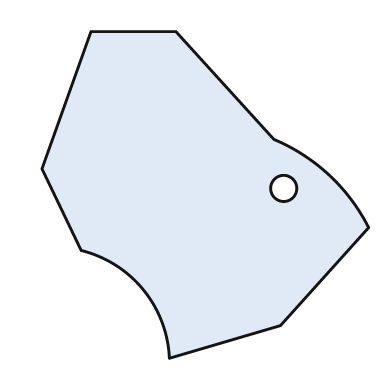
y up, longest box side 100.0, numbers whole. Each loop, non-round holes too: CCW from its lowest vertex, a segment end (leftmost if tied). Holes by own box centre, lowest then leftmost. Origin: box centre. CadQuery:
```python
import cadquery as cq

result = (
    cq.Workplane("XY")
    .moveTo(-11.0, -50.0)
    .lineTo(23.0, -40.0)
    .lineTo(50.0, -10.0)
    .threePointArc((38.0, 6.0), (21.0, 17.0))
    .lineTo(-9.0, 50.0)
    .lineTo(-35.0, 50.0)
    .lineTo(-50.0, 8.0)
    .lineTo(-38.0, -17.0)
    .threePointArc((-19.0, -29.0), (-11.0, -50.0))
    .close()
    .moveTo(24.0, 2.0)
    .circle(4.0)
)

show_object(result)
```